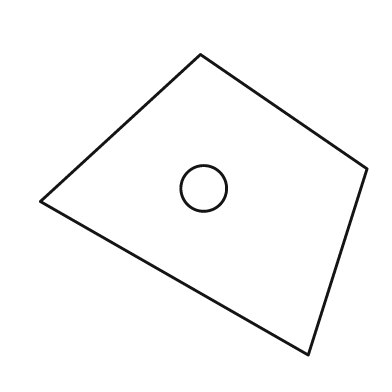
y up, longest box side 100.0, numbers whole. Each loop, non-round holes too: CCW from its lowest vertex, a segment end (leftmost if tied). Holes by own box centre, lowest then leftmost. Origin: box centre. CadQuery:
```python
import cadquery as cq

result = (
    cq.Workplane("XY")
    .moveTo(32.0, -46.0)
    .lineTo(50.0, 11.0)
    .lineTo(-1.0, 46.0)
    .lineTo(-50.0, 1.0)
    .close()
    .moveTo(0.0, 5.0)
    .circle(7.0)
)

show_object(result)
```